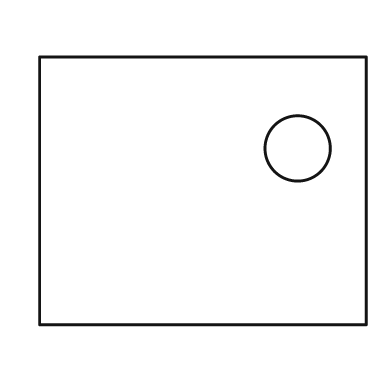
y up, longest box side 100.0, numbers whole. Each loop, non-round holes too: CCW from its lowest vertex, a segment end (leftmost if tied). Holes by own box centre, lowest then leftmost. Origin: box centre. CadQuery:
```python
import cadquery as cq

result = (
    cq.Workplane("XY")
    .moveTo(-50.0, -41.0)
    .lineTo(50.0, -41.0)
    .lineTo(50.0, 41.0)
    .lineTo(-50.0, 41.0)
    .close()
    .moveTo(29.0, 13.0)
    .circle(10.0)
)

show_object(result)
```